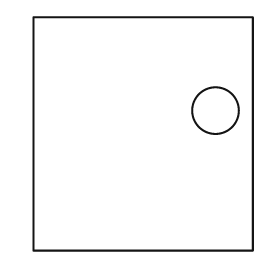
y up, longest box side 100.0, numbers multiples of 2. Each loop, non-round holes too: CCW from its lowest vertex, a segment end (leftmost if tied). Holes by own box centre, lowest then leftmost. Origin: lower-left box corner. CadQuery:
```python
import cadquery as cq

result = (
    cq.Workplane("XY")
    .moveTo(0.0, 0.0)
    .lineTo(94.0, 0.0)
    .lineTo(94.0, 100.0)
    .lineTo(0.0, 100.0)
    .close()
    .moveTo(78.0, 60.0)
    .circle(10.0)
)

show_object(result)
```